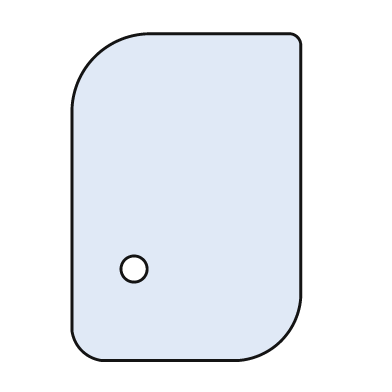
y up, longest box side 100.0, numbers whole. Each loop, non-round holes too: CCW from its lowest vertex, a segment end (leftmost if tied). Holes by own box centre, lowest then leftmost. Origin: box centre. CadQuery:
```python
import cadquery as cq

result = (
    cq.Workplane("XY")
    .moveTo(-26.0, -50.0)
    .lineTo(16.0, -50.0)
    .threePointArc((29.0, -44.0), (35.0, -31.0))
    .lineTo(35.0, 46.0)
    .threePointArc((34.0, 49.0), (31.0, 50.0))
    .lineTo(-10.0, 50.0)
    .threePointArc((-28.0, 43.0), (-35.0, 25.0))
    .lineTo(-35.0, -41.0)
    .threePointArc((-32.0, -47.0), (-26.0, -50.0))
    .close()
    .moveTo(-16.0, -22.0)
    .circle(4.0)
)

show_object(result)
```